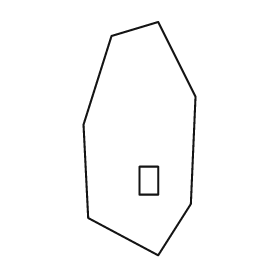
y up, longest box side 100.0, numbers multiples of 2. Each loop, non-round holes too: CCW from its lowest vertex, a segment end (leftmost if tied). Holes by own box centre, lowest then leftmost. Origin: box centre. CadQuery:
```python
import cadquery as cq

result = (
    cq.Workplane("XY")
    .moveTo(8.0, -50.0)
    .lineTo(22.0, -28.0)
    .lineTo(24.0, 18.0)
    .lineTo(8.0, 50.0)
    .lineTo(-12.0, 44.0)
    .lineTo(-24.0, 6.0)
    .lineTo(-22.0, -34.0)
    .close()
    .moveTo(0.0, -24.0)
    .lineTo(8.0, -24.0)
    .lineTo(8.0, -12.0)
    .lineTo(0.0, -12.0)
    .close()
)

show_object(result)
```